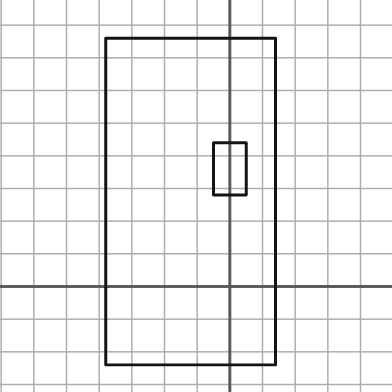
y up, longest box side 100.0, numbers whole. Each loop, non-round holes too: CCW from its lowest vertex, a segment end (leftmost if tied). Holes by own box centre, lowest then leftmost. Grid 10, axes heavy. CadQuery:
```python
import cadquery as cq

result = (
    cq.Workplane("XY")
    .moveTo(-38.0, -24.0)
    .lineTo(14.0, -24.0)
    .lineTo(14.0, 76.0)
    .lineTo(-38.0, 76.0)
    .close()
    .moveTo(-5.0, 28.0)
    .lineTo(5.0, 28.0)
    .lineTo(5.0, 44.0)
    .lineTo(-5.0, 44.0)
    .close()
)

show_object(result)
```